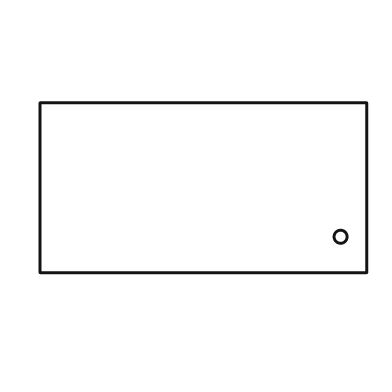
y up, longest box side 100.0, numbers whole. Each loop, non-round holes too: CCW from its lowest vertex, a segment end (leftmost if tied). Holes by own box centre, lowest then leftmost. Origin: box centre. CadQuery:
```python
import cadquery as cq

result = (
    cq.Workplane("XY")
    .moveTo(-50.0, -26.0)
    .lineTo(50.0, -26.0)
    .lineTo(50.0, 26.0)
    .lineTo(-50.0, 26.0)
    .close()
    .moveTo(42.0, -15.0)
    .circle(2.0)
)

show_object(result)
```